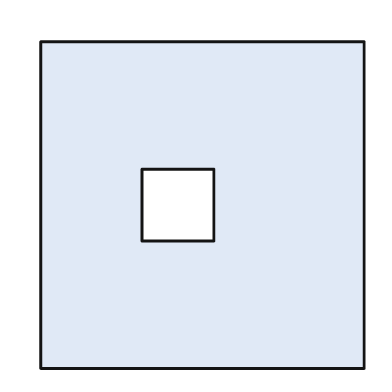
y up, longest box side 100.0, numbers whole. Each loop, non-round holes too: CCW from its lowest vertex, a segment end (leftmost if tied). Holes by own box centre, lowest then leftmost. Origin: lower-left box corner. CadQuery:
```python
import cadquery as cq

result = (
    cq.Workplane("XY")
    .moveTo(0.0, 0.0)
    .lineTo(99.0, 0.0)
    .lineTo(99.0, 100.0)
    .lineTo(0.0, 100.0)
    .close()
    .moveTo(31.0, 39.0)
    .lineTo(53.0, 39.0)
    .lineTo(53.0, 61.0)
    .lineTo(31.0, 61.0)
    .close()
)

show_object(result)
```